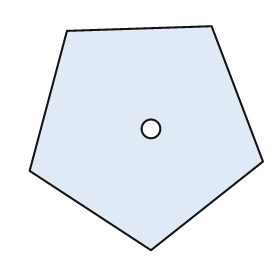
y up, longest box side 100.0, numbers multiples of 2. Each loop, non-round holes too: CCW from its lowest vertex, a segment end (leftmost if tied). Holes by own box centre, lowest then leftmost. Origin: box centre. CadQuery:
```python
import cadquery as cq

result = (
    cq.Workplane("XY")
    .moveTo(2.0, -48.0)
    .lineTo(50.0, -10.0)
    .lineTo(28.0, 48.0)
    .lineTo(-34.0, 46.0)
    .lineTo(-50.0, -14.0)
    .close()
    .moveTo(2.0, 4.0)
    .circle(4.0)
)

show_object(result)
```